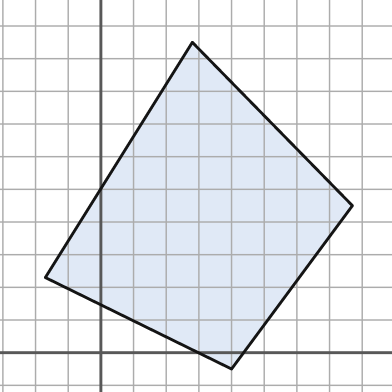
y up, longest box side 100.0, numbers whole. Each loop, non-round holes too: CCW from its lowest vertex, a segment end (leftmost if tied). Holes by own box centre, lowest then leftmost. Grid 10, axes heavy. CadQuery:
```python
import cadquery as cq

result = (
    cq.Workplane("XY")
    .moveTo(40.0, -5.0)
    .lineTo(77.0, 45.0)
    .lineTo(28.0, 95.0)
    .lineTo(-17.0, 23.0)
    .close()
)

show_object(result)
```